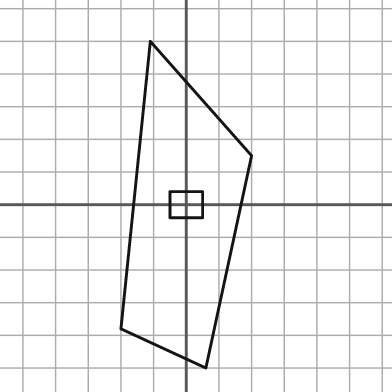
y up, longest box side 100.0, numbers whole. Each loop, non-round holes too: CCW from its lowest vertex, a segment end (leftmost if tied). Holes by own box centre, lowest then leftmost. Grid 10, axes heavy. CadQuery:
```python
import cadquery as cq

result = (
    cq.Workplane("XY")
    .moveTo(6.0, -50.0)
    .lineTo(20.0, 15.0)
    .lineTo(-11.0, 50.0)
    .lineTo(-20.0, -38.0)
    .close()
    .moveTo(-5.0, -4.0)
    .lineTo(5.0, -4.0)
    .lineTo(5.0, 4.0)
    .lineTo(-5.0, 4.0)
    .close()
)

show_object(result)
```